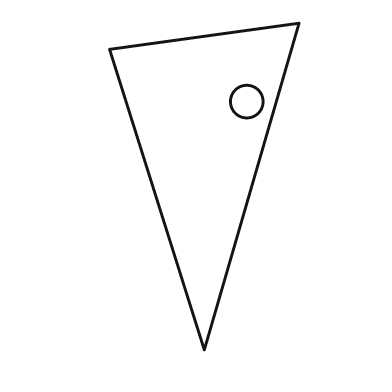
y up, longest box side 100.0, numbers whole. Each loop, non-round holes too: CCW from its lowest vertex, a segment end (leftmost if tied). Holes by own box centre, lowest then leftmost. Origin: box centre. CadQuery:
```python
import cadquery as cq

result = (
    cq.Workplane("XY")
    .moveTo(0.0, -50.0)
    .lineTo(29.0, 50.0)
    .lineTo(-29.0, 42.0)
    .close()
    .moveTo(13.0, 26.0)
    .circle(5.0)
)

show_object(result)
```